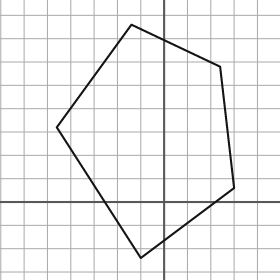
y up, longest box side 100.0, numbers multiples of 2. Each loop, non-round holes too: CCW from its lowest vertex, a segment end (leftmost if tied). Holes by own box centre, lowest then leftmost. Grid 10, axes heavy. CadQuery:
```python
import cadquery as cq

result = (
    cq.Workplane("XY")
    .moveTo(-10.0, -24.0)
    .lineTo(30.0, 6.0)
    .lineTo(24.0, 58.0)
    .lineTo(-14.0, 76.0)
    .lineTo(-46.0, 32.0)
    .close()
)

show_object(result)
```